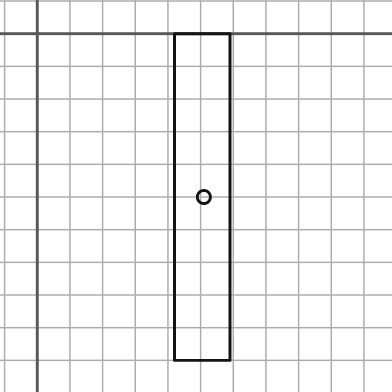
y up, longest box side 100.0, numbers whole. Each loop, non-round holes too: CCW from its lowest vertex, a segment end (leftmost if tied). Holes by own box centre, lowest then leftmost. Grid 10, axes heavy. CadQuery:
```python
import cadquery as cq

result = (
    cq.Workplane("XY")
    .moveTo(42.0, -100.0)
    .lineTo(59.0, -100.0)
    .lineTo(59.0, 0.0)
    .lineTo(42.0, 0.0)
    .close()
    .moveTo(51.0, -50.0)
    .circle(2.0)
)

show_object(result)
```